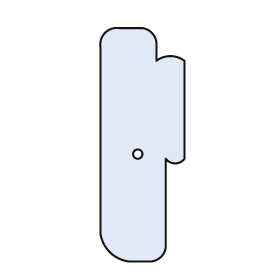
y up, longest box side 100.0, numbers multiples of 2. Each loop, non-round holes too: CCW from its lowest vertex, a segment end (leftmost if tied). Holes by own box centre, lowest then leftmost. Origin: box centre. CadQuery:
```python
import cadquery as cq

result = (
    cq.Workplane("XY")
    .moveTo(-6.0, -50.0)
    .lineTo(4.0, -50.0)
    .threePointArc((8.0, -48.0), (10.0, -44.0))
    .lineTo(10.0, -6.0)
    .threePointArc((14.0, -8.0), (18.0, -6.0))
    .lineTo(18.0, 36.0)
    .threePointArc((12.0, 38.0), (6.0, 36.0))
    .lineTo(6.0, 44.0)
    .threePointArc((4.0, 48.0), (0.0, 50.0))
    .lineTo(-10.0, 50.0)
    .threePointArc((-16.0, 48.0), (-18.0, 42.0))
    .lineTo(-18.0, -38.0)
    .threePointArc((-14.0, -46.0), (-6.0, -50.0))
    .close()
    .moveTo(-2.0, -4.0)
    .circle(2.0)
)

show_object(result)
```